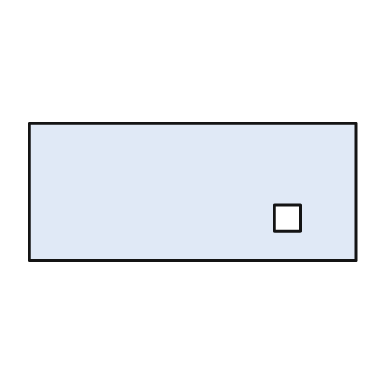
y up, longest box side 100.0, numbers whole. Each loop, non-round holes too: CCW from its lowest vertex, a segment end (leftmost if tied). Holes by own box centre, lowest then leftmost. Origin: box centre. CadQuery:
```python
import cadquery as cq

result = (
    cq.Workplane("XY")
    .moveTo(-50.0, -21.0)
    .lineTo(50.0, -21.0)
    .lineTo(50.0, 21.0)
    .lineTo(-50.0, 21.0)
    .close()
    .moveTo(25.0, -12.0)
    .lineTo(33.0, -12.0)
    .lineTo(33.0, -4.0)
    .lineTo(25.0, -4.0)
    .close()
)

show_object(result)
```